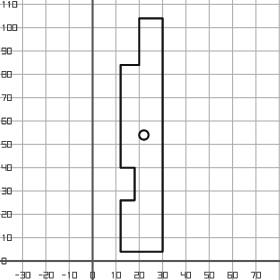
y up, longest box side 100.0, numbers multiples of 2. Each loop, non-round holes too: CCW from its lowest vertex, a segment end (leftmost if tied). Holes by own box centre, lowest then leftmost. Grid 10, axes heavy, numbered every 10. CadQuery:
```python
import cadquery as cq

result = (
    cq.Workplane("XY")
    .moveTo(12.0, 4.0)
    .lineTo(30.0, 4.0)
    .lineTo(30.0, 104.0)
    .lineTo(20.0, 104.0)
    .lineTo(20.0, 84.0)
    .lineTo(12.0, 84.0)
    .lineTo(12.0, 40.0)
    .lineTo(18.0, 40.0)
    .lineTo(18.0, 26.0)
    .lineTo(12.0, 26.0)
    .close()
    .moveTo(22.0, 54.0)
    .circle(2.0)
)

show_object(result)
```